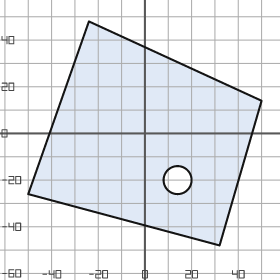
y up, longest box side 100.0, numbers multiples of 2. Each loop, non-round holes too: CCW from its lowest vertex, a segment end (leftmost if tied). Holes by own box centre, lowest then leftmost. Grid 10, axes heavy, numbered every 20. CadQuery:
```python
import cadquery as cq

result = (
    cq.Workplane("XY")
    .moveTo(32.0, -48.0)
    .lineTo(50.0, 14.0)
    .lineTo(-24.0, 48.0)
    .lineTo(-50.0, -26.0)
    .close()
    .moveTo(14.0, -20.0)
    .circle(6.0)
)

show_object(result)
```